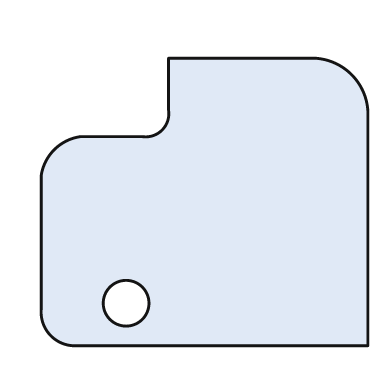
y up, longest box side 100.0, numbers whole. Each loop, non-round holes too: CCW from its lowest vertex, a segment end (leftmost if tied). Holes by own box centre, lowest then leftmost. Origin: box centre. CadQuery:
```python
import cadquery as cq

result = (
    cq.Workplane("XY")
    .moveTo(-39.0, -44.0)
    .lineTo(50.0, -44.0)
    .lineTo(50.0, 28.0)
    .threePointArc((45.0, 39.0), (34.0, 44.0))
    .lineTo(-11.0, 44.0)
    .lineTo(-11.0, 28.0)
    .threePointArc((-13.0, 22.0), (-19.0, 20.0))
    .lineTo(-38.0, 20.0)
    .threePointArc((-46.0, 16.0), (-50.0, 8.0))
    .lineTo(-50.0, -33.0)
    .threePointArc((-47.0, -41.0), (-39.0, -44.0))
    .close()
    .moveTo(-24.0, -31.0)
    .circle(7.0)
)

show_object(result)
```